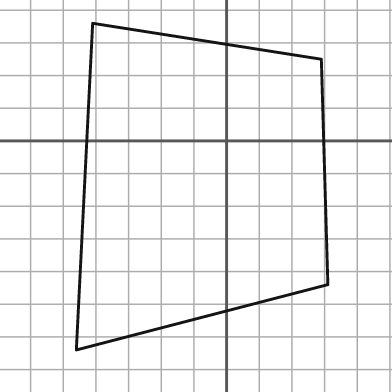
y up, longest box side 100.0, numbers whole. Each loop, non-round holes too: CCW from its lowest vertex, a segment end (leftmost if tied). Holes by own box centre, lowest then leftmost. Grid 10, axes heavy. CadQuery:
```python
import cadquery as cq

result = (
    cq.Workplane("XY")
    .moveTo(-46.0, -64.0)
    .lineTo(31.0, -44.0)
    .lineTo(29.0, 25.0)
    .lineTo(-41.0, 36.0)
    .close()
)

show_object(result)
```